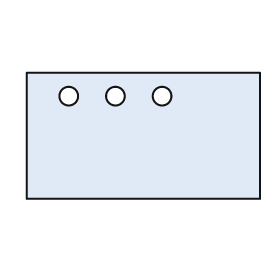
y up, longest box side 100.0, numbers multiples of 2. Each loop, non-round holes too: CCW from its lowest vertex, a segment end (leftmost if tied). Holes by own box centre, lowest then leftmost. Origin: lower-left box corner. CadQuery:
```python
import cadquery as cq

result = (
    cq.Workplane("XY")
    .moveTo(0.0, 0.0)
    .lineTo(100.0, 0.0)
    .lineTo(100.0, 54.0)
    .lineTo(0.0, 54.0)
    .close()
    .moveTo(18.0, 44.0)
    .circle(4.0)
    .moveTo(38.0, 44.0)
    .circle(4.0)
    .moveTo(58.0, 44.0)
    .circle(4.0)
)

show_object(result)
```